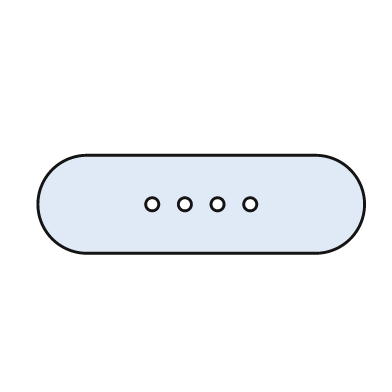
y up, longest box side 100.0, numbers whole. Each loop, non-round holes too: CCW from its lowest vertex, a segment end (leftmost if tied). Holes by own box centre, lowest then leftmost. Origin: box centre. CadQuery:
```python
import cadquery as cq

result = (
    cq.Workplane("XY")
    .moveTo(-35.0, -15.0)
    .lineTo(35.0, -15.0)
    .threePointArc((50.0, 0.0), (35.0, 15.0))
    .lineTo(-35.0, 15.0)
    .threePointArc((-50.0, 0.0), (-35.0, -15.0))
    .close()
    .moveTo(-15.0, 0.0)
    .circle(2.0)
    .moveTo(-5.0, 0.0)
    .circle(2.0)
    .moveTo(5.0, 0.0)
    .circle(2.0)
    .moveTo(15.0, 0.0)
    .circle(2.0)
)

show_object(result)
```